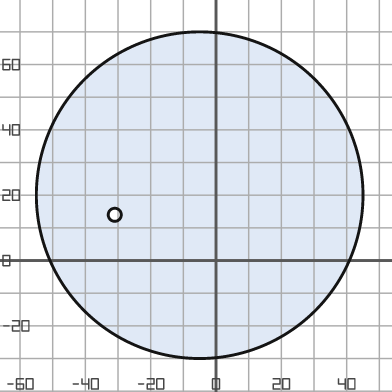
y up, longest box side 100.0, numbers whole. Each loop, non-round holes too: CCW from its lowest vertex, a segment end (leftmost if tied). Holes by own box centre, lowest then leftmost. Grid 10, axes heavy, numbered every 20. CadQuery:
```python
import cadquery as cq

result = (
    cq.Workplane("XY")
    .moveTo(-5.0, 20.0)
    .circle(50.0)
    .moveTo(-31.0, 14.0)
    .circle(2.0)
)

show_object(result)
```